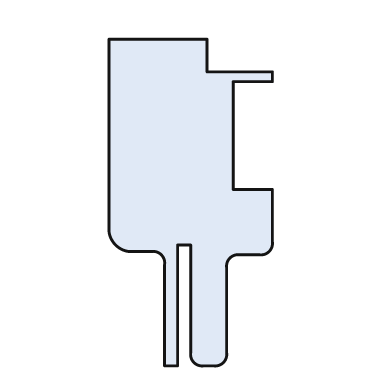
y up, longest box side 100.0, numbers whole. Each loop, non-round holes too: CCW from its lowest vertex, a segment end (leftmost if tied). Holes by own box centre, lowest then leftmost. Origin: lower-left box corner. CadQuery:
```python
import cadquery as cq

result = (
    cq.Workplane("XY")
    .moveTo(17.0, 0.0)
    .lineTo(21.0, 0.0)
    .lineTo(21.0, 37.0)
    .lineTo(25.0, 37.0)
    .lineTo(25.0, 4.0)
    .threePointArc((26.0, 1.0), (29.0, 0.0))
    .lineTo(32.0, 0.0)
    .threePointArc((35.0, 1.0), (36.0, 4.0))
    .lineTo(36.0, 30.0)
    .threePointArc((37.0, 33.0), (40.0, 34.0))
    .lineTo(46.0, 34.0)
    .threePointArc((49.0, 35.0), (50.0, 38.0))
    .lineTo(50.0, 54.0)
    .lineTo(38.0, 54.0)
    .lineTo(38.0, 87.0)
    .lineTo(50.0, 87.0)
    .lineTo(50.0, 90.0)
    .lineTo(30.0, 90.0)
    .lineTo(30.0, 100.0)
    .lineTo(0.0, 100.0)
    .lineTo(0.0, 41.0)
    .threePointArc((2.0, 37.0), (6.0, 35.0))
    .lineTo(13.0, 35.0)
    .threePointArc((16.0, 34.0), (17.0, 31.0))
    .close()
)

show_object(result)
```